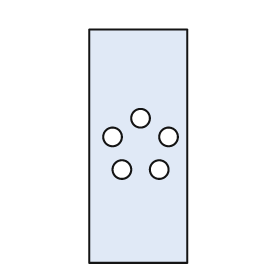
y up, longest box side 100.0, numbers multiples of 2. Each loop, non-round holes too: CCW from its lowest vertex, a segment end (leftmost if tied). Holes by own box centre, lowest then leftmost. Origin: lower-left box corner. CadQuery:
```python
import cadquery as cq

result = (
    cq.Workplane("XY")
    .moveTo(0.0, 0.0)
    .lineTo(42.0, 0.0)
    .lineTo(42.0, 100.0)
    .lineTo(0.0, 100.0)
    .close()
    .moveTo(14.0, 40.0)
    .circle(4.0)
    .moveTo(30.0, 40.0)
    .circle(4.0)
    .moveTo(10.0, 54.0)
    .circle(4.0)
    .moveTo(34.0, 54.0)
    .circle(4.0)
    .moveTo(22.0, 62.0)
    .circle(4.0)
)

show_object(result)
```